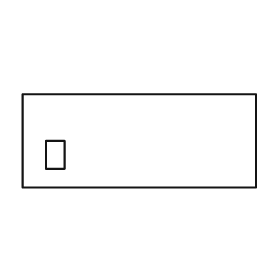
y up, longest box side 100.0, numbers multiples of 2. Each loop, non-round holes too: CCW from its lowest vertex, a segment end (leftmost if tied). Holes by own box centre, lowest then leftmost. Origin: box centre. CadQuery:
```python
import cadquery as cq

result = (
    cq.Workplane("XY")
    .moveTo(-50.0, -20.0)
    .lineTo(50.0, -20.0)
    .lineTo(50.0, 20.0)
    .lineTo(-50.0, 20.0)
    .close()
    .moveTo(-40.0, -12.0)
    .lineTo(-32.0, -12.0)
    .lineTo(-32.0, 0.0)
    .lineTo(-40.0, 0.0)
    .close()
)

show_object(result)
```